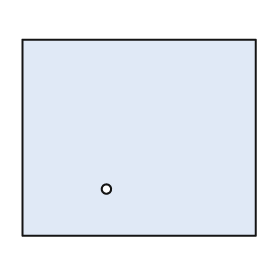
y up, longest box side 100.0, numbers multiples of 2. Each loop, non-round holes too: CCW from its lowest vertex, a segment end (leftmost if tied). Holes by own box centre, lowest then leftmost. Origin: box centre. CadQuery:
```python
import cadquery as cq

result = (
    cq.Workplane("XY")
    .moveTo(-50.0, -42.0)
    .lineTo(50.0, -42.0)
    .lineTo(50.0, 42.0)
    .lineTo(-50.0, 42.0)
    .close()
    .moveTo(-14.0, -22.0)
    .circle(2.0)
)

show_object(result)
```